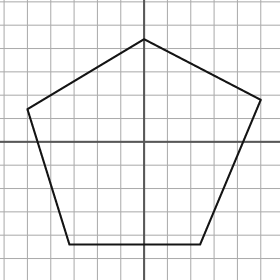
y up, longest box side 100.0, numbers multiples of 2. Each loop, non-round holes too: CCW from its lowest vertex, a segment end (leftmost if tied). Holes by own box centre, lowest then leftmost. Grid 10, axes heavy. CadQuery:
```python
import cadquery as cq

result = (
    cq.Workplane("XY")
    .moveTo(-32.0, -44.0)
    .lineTo(24.0, -44.0)
    .lineTo(50.0, 18.0)
    .lineTo(0.0, 44.0)
    .lineTo(-50.0, 14.0)
    .close()
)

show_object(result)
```